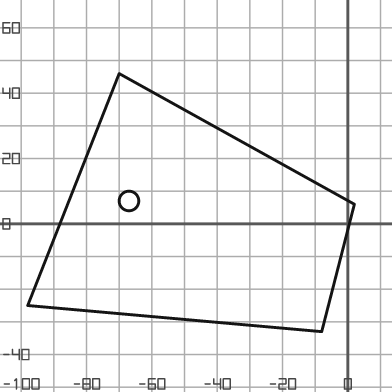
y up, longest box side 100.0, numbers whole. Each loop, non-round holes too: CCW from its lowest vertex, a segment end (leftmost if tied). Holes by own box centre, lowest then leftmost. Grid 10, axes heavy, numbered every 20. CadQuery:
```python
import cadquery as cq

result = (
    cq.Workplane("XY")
    .moveTo(-8.0, -33.0)
    .lineTo(2.0, 6.0)
    .lineTo(-70.0, 46.0)
    .lineTo(-98.0, -25.0)
    .close()
    .moveTo(-67.0, 7.0)
    .circle(3.0)
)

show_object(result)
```